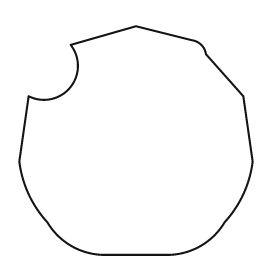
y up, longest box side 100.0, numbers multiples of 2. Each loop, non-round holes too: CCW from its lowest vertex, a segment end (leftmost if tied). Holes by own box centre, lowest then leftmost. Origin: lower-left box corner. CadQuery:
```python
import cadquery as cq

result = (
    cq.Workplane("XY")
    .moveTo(36.0, 0.0)
    .lineTo(64.0, 0.0)
    .threePointArc((78.0, 4.0), (88.0, 14.0))
    .threePointArc((96.0, 26.0), (100.0, 40.0))
    .lineTo(96.0, 68.0)
    .lineTo(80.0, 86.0)
    .threePointArc((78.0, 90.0), (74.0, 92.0))
    .lineTo(50.0, 98.0)
    .lineTo(22.0, 90.0)
    .threePointArc((22.0, 72.0), (4.0, 68.0))
    .lineTo(0.0, 40.0)
    .threePointArc((4.0, 26.0), (12.0, 14.0))
    .threePointArc((22.0, 4.0), (36.0, 0.0))
    .close()
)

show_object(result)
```